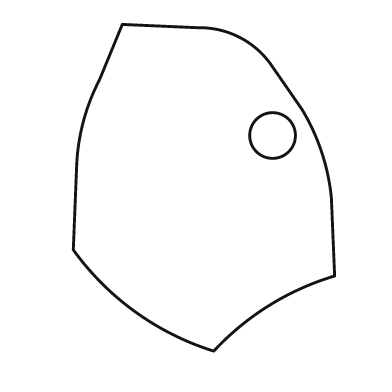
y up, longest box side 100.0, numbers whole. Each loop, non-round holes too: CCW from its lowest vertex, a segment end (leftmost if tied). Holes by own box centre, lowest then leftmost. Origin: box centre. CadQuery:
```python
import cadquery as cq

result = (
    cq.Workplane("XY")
    .moveTo(3.0, -50.0)
    .threePointArc((20.0, -36.0), (40.0, -27.0))
    .lineTo(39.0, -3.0)
    .threePointArc((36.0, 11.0), (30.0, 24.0))
    .lineTo(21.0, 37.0)
    .threePointArc((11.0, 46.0), (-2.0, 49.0))
    .lineTo(-25.0, 50.0)
    .lineTo(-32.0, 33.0)
    .threePointArc((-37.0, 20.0), (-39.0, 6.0))
    .lineTo(-40.0, -19.0)
    .threePointArc((-21.0, -38.0), (3.0, -50.0))
    .close()
    .moveTo(21.0, 16.0)
    .circle(7.0)
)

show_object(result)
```